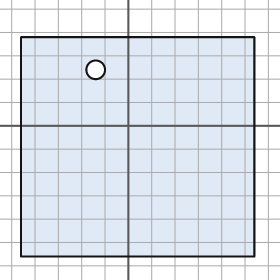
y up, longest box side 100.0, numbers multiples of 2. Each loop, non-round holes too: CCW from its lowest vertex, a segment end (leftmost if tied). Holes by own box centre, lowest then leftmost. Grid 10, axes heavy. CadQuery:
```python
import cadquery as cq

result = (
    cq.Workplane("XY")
    .moveTo(-46.0, -56.0)
    .lineTo(54.0, -56.0)
    .lineTo(54.0, 38.0)
    .lineTo(-46.0, 38.0)
    .close()
    .moveTo(-14.0, 24.0)
    .circle(4.0)
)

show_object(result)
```